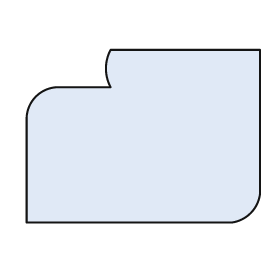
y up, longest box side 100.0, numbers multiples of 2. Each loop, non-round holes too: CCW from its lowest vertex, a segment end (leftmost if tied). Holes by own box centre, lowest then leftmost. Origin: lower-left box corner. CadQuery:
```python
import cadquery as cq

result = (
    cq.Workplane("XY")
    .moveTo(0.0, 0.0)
    .lineTo(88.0, 0.0)
    .threePointArc((96.0, 4.0), (100.0, 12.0))
    .lineTo(100.0, 74.0)
    .lineTo(36.0, 74.0)
    .threePointArc((34.0, 66.0), (36.0, 58.0))
    .lineTo(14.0, 58.0)
    .threePointArc((4.0, 54.0), (0.0, 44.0))
    .close()
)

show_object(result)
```